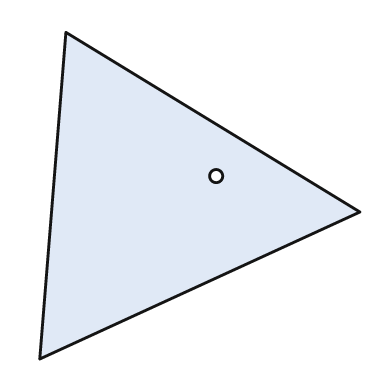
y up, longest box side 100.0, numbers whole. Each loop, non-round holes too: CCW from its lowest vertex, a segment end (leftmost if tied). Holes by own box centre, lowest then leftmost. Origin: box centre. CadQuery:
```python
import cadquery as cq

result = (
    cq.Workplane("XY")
    .moveTo(-49.0, -50.0)
    .lineTo(49.0, -5.0)
    .lineTo(-41.0, 50.0)
    .close()
    .moveTo(5.0, 6.0)
    .circle(2.0)
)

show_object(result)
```